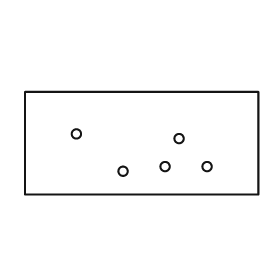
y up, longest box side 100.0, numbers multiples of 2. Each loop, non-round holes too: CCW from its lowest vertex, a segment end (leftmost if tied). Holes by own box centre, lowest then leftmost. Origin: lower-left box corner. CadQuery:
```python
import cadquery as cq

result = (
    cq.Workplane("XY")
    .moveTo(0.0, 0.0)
    .lineTo(100.0, 0.0)
    .lineTo(100.0, 44.0)
    .lineTo(0.0, 44.0)
    .close()
    .moveTo(42.0, 10.0)
    .circle(2.0)
    .moveTo(60.0, 12.0)
    .circle(2.0)
    .moveTo(78.0, 12.0)
    .circle(2.0)
    .moveTo(66.0, 24.0)
    .circle(2.0)
    .moveTo(22.0, 26.0)
    .circle(2.0)
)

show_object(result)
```